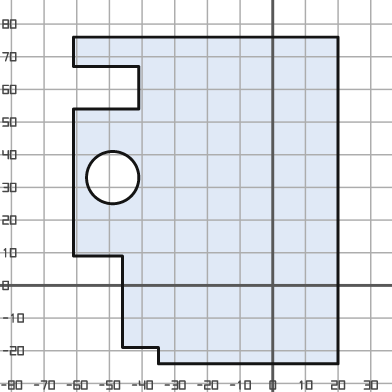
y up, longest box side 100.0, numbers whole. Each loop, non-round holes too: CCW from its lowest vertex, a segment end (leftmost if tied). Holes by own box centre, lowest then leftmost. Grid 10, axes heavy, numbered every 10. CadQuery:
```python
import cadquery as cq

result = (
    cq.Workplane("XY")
    .moveTo(-35.0, -24.0)
    .lineTo(20.0, -24.0)
    .lineTo(20.0, 76.0)
    .lineTo(-61.0, 76.0)
    .lineTo(-61.0, 67.0)
    .lineTo(-41.0, 67.0)
    .lineTo(-41.0, 54.0)
    .lineTo(-61.0, 54.0)
    .lineTo(-61.0, 9.0)
    .lineTo(-46.0, 9.0)
    .lineTo(-46.0, -19.0)
    .lineTo(-35.0, -19.0)
    .close()
    .moveTo(-49.0, 33.0)
    .circle(8.0)
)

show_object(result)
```